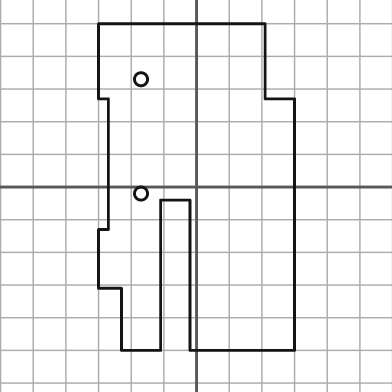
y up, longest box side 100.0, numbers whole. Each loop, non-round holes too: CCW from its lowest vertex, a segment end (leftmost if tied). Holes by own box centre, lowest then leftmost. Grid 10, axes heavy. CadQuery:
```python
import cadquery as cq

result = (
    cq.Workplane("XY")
    .moveTo(-23.0, -50.0)
    .lineTo(-11.0, -50.0)
    .lineTo(-11.0, -4.0)
    .lineTo(-2.0, -4.0)
    .lineTo(-2.0, -50.0)
    .lineTo(30.0, -50.0)
    .lineTo(30.0, 27.0)
    .lineTo(21.0, 27.0)
    .lineTo(21.0, 50.0)
    .lineTo(-30.0, 50.0)
    .lineTo(-30.0, 27.0)
    .lineTo(-27.0, 27.0)
    .lineTo(-27.0, -13.0)
    .lineTo(-30.0, -13.0)
    .lineTo(-30.0, -31.0)
    .lineTo(-23.0, -31.0)
    .close()
    .moveTo(-17.0, -2.0)
    .circle(2.0)
    .moveTo(-17.0, 33.0)
    .circle(2.0)
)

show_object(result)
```